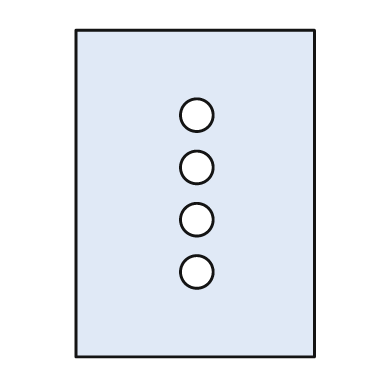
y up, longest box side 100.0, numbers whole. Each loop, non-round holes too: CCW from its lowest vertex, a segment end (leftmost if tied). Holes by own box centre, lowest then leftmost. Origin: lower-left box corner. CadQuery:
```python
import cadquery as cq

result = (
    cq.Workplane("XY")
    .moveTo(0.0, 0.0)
    .lineTo(73.0, 0.0)
    .lineTo(73.0, 100.0)
    .lineTo(0.0, 100.0)
    .close()
    .moveTo(37.0, 26.0)
    .circle(5.0)
    .moveTo(37.0, 42.0)
    .circle(5.0)
    .moveTo(37.0, 58.0)
    .circle(5.0)
    .moveTo(37.0, 74.0)
    .circle(5.0)
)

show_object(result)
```